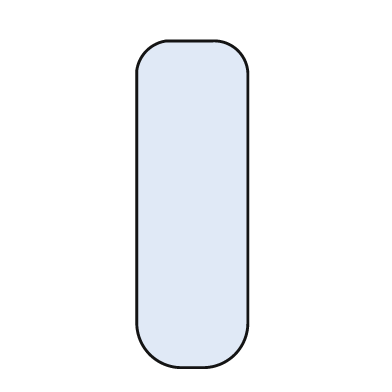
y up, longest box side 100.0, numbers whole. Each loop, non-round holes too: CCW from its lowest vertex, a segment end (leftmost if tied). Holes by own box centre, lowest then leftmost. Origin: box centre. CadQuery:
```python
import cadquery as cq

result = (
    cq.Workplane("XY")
    .moveTo(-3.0, -50.0)
    .lineTo(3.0, -50.0)
    .threePointArc((13.0, -46.0), (17.0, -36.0))
    .lineTo(17.0, 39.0)
    .threePointArc((14.0, 47.0), (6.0, 50.0))
    .lineTo(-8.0, 50.0)
    .threePointArc((-14.0, 47.0), (-17.0, 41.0))
    .lineTo(-17.0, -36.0)
    .threePointArc((-13.0, -46.0), (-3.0, -50.0))
    .close()
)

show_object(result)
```